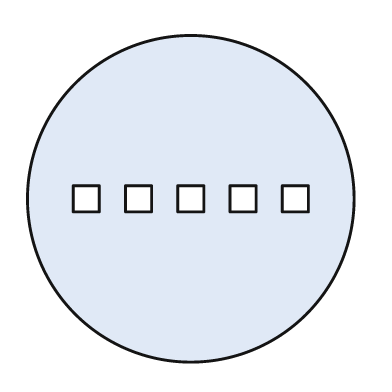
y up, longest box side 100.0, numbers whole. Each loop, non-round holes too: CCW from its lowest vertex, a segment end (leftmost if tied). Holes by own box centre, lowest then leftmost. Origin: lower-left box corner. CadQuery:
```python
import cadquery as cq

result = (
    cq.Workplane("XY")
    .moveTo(50.0, 50.0)
    .circle(50.0)
    .moveTo(14.0, 46.0)
    .lineTo(22.0, 46.0)
    .lineTo(22.0, 54.0)
    .lineTo(14.0, 54.0)
    .close()
    .moveTo(30.0, 46.0)
    .lineTo(38.0, 46.0)
    .lineTo(38.0, 54.0)
    .lineTo(30.0, 54.0)
    .close()
    .moveTo(46.0, 46.0)
    .lineTo(54.0, 46.0)
    .lineTo(54.0, 54.0)
    .lineTo(46.0, 54.0)
    .close()
    .moveTo(62.0, 46.0)
    .lineTo(70.0, 46.0)
    .lineTo(70.0, 54.0)
    .lineTo(62.0, 54.0)
    .close()
    .moveTo(78.0, 46.0)
    .lineTo(86.0, 46.0)
    .lineTo(86.0, 54.0)
    .lineTo(78.0, 54.0)
    .close()
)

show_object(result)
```